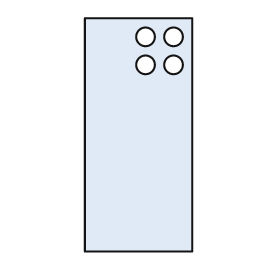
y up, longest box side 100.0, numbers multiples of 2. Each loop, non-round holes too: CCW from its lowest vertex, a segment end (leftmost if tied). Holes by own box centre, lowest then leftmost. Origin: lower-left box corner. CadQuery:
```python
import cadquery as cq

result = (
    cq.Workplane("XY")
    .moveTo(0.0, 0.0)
    .lineTo(46.0, 0.0)
    .lineTo(46.0, 100.0)
    .lineTo(0.0, 100.0)
    .close()
    .moveTo(26.0, 80.0)
    .circle(4.0)
    .moveTo(38.0, 80.0)
    .circle(4.0)
    .moveTo(26.0, 92.0)
    .circle(4.0)
    .moveTo(38.0, 92.0)
    .circle(4.0)
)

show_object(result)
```